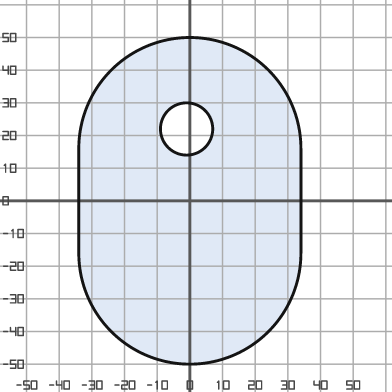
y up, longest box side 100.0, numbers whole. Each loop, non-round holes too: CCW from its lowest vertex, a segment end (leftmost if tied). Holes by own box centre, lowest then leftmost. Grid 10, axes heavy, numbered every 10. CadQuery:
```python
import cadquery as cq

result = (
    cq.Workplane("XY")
    .moveTo(-34.0, -16.0)
    .threePointArc((0.0, -50.0), (34.0, -16.0))
    .lineTo(34.0, 16.0)
    .threePointArc((0.0, 50.0), (-34.0, 16.0))
    .close()
    .moveTo(-1.0, 22.0)
    .circle(8.0)
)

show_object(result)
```